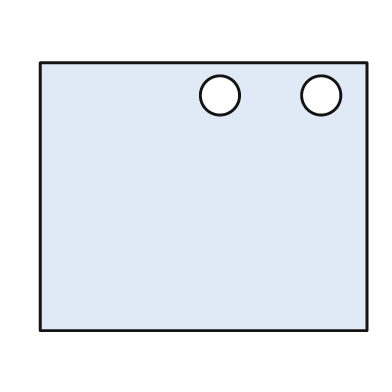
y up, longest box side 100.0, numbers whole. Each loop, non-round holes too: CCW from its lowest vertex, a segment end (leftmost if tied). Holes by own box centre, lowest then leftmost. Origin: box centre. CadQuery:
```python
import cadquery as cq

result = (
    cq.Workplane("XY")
    .moveTo(-50.0, -41.0)
    .lineTo(50.0, -41.0)
    .lineTo(50.0, 41.0)
    .lineTo(-50.0, 41.0)
    .close()
    .moveTo(5.0, 31.0)
    .circle(6.0)
    .moveTo(36.0, 31.0)
    .circle(6.0)
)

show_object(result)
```